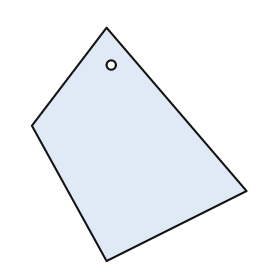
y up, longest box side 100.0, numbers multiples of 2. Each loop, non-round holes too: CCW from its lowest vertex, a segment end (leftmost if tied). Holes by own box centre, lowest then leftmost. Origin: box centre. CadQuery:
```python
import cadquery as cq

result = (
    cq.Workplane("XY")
    .moveTo(-14.0, -50.0)
    .lineTo(46.0, -20.0)
    .lineTo(-14.0, 50.0)
    .lineTo(-46.0, 8.0)
    .close()
    .moveTo(-12.0, 34.0)
    .circle(2.0)
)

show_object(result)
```